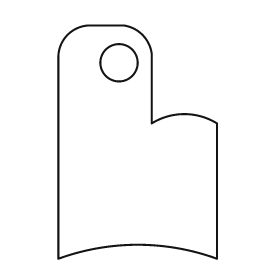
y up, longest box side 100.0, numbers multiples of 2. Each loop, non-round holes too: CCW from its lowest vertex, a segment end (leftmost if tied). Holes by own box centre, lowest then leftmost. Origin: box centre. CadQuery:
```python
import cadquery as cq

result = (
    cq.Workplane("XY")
    .moveTo(-34.0, -50.0)
    .threePointArc((0.0, -44.0), (34.0, -50.0))
    .lineTo(34.0, 8.0)
    .threePointArc((20.0, 12.0), (6.0, 8.0))
    .lineTo(6.0, 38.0)
    .threePointArc((2.0, 46.0), (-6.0, 50.0))
    .lineTo(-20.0, 50.0)
    .threePointArc((-30.0, 46.0), (-34.0, 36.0))
    .close()
    .moveTo(-8.0, 34.0)
    .circle(8.0)
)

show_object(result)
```